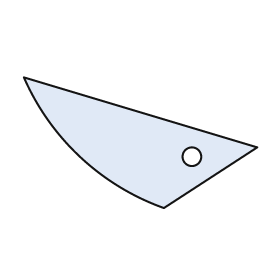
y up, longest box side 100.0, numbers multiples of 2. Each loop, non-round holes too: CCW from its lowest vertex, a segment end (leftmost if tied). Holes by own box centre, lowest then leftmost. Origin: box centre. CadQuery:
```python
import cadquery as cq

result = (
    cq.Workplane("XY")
    .moveTo(10.0, -28.0)
    .lineTo(50.0, -2.0)
    .lineTo(-50.0, 28.0)
    .threePointArc((-26.0, -6.0), (10.0, -28.0))
    .close()
    .moveTo(22.0, -6.0)
    .circle(4.0)
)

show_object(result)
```